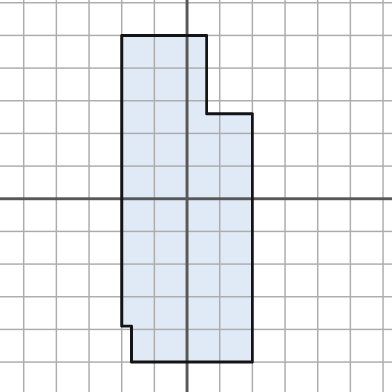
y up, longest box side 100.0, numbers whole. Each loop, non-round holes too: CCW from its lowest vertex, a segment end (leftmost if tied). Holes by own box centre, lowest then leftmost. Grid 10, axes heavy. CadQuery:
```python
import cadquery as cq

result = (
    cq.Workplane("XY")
    .moveTo(-17.0, -50.0)
    .lineTo(20.0, -50.0)
    .lineTo(20.0, 26.0)
    .lineTo(6.0, 26.0)
    .lineTo(6.0, 50.0)
    .lineTo(-20.0, 50.0)
    .lineTo(-20.0, -39.0)
    .lineTo(-17.0, -39.0)
    .close()
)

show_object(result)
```